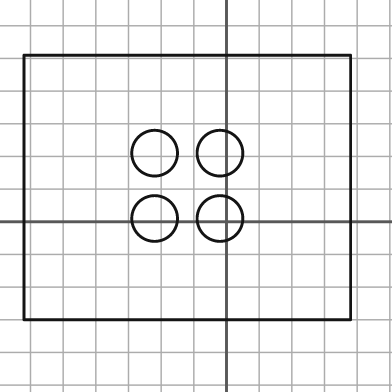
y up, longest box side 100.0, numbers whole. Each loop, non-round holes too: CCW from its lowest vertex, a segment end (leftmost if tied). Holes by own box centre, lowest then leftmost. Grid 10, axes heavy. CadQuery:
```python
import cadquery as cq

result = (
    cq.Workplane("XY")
    .moveTo(-62.0, -30.0)
    .lineTo(38.0, -30.0)
    .lineTo(38.0, 51.0)
    .lineTo(-62.0, 51.0)
    .close()
    .moveTo(-22.0, 1.0)
    .circle(7.0)
    .moveTo(-2.0, 1.0)
    .circle(7.0)
    .moveTo(-22.0, 21.0)
    .circle(7.0)
    .moveTo(-2.0, 21.0)
    .circle(7.0)
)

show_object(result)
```